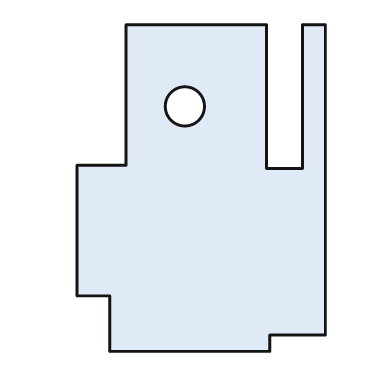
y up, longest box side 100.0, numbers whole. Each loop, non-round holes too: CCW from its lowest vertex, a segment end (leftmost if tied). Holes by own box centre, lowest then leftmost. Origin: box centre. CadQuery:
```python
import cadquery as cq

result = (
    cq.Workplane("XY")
    .moveTo(-28.0, -50.0)
    .lineTo(21.0, -50.0)
    .lineTo(21.0, -45.0)
    .lineTo(38.0, -45.0)
    .lineTo(38.0, 50.0)
    .lineTo(31.0, 50.0)
    .lineTo(31.0, 6.0)
    .lineTo(20.0, 6.0)
    .lineTo(20.0, 50.0)
    .lineTo(-23.0, 50.0)
    .lineTo(-23.0, 7.0)
    .lineTo(-38.0, 7.0)
    .lineTo(-38.0, -33.0)
    .lineTo(-28.0, -33.0)
    .close()
    .moveTo(-5.0, 25.0)
    .circle(6.0)
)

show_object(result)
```